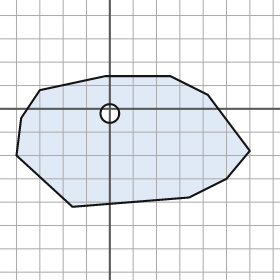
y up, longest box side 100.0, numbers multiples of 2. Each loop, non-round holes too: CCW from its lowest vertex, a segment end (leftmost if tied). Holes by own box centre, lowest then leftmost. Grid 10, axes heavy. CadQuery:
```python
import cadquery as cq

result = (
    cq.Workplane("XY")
    .moveTo(-16.0, -42.0)
    .lineTo(34.0, -38.0)
    .lineTo(50.0, -30.0)
    .lineTo(60.0, -18.0)
    .lineTo(42.0, 6.0)
    .lineTo(26.0, 14.0)
    .lineTo(-2.0, 14.0)
    .lineTo(-30.0, 8.0)
    .lineTo(-38.0, -4.0)
    .lineTo(-40.0, -20.0)
    .close()
    .moveTo(0.0, -2.0)
    .circle(4.0)
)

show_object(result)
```